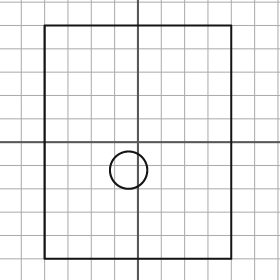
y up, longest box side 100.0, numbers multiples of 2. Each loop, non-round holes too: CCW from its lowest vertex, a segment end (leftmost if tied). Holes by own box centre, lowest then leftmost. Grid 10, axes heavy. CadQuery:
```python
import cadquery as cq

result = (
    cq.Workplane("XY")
    .moveTo(-40.0, -50.0)
    .lineTo(40.0, -50.0)
    .lineTo(40.0, 50.0)
    .lineTo(-40.0, 50.0)
    .close()
    .moveTo(-4.0, -12.0)
    .circle(8.0)
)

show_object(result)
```